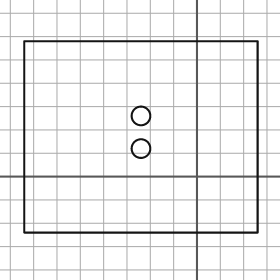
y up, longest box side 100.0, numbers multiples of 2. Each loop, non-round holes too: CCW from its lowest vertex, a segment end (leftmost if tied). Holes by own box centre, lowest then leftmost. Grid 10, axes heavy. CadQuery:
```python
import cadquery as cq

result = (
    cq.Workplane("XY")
    .moveTo(-74.0, -24.0)
    .lineTo(26.0, -24.0)
    .lineTo(26.0, 58.0)
    .lineTo(-74.0, 58.0)
    .close()
    .moveTo(-24.0, 12.0)
    .circle(4.0)
    .moveTo(-24.0, 26.0)
    .circle(4.0)
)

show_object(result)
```